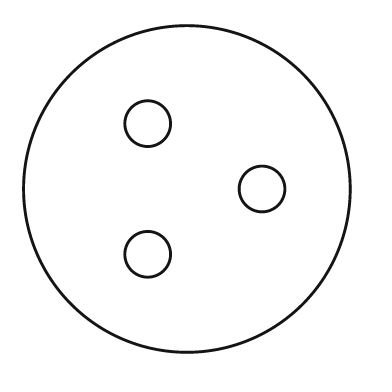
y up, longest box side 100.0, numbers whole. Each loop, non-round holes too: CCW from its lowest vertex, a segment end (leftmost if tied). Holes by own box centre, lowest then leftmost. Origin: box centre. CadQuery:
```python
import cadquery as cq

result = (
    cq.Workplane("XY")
    .moveTo(0.0, 0.0)
    .circle(50.0)
    .moveTo(-12.0, -20.0)
    .circle(7.0)
    .moveTo(23.0, 0.0)
    .circle(7.0)
    .moveTo(-12.0, 20.0)
    .circle(7.0)
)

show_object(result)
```